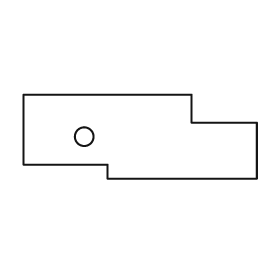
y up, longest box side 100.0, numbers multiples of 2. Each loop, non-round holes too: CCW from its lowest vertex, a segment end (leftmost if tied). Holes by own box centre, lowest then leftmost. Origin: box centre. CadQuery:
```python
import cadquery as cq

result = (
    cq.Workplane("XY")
    .moveTo(-14.0, -18.0)
    .lineTo(50.0, -18.0)
    .lineTo(50.0, 6.0)
    .lineTo(22.0, 6.0)
    .lineTo(22.0, 18.0)
    .lineTo(-50.0, 18.0)
    .lineTo(-50.0, -12.0)
    .lineTo(-14.0, -12.0)
    .close()
    .moveTo(-24.0, 0.0)
    .circle(4.0)
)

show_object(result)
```